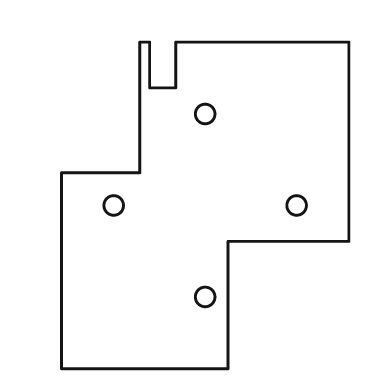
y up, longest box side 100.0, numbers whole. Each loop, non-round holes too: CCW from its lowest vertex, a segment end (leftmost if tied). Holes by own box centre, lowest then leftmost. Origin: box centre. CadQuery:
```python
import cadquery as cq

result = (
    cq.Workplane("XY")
    .moveTo(-44.0, -50.0)
    .lineTo(7.0, -50.0)
    .lineTo(7.0, -11.0)
    .lineTo(44.0, -11.0)
    .lineTo(44.0, 50.0)
    .lineTo(-9.0, 50.0)
    .lineTo(-9.0, 36.0)
    .lineTo(-17.0, 36.0)
    .lineTo(-17.0, 50.0)
    .lineTo(-20.0, 50.0)
    .lineTo(-20.0, 10.0)
    .lineTo(-44.0, 10.0)
    .close()
    .moveTo(0.0, -28.0)
    .circle(3.0)
    .moveTo(-28.0, 0.0)
    .circle(3.0)
    .moveTo(28.0, 0.0)
    .circle(3.0)
    .moveTo(0.0, 28.0)
    .circle(3.0)
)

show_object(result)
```